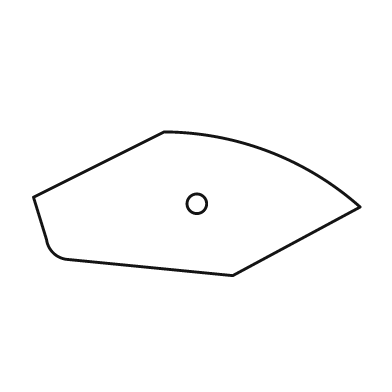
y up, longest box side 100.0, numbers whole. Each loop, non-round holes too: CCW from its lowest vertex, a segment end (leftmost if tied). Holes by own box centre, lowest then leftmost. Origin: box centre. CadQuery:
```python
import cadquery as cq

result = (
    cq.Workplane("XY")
    .moveTo(11.0, -22.0)
    .lineTo(50.0, -1.0)
    .threePointArc((22.0, 16.0), (-10.0, 22.0))
    .lineTo(-50.0, 2.0)
    .lineTo(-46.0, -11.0)
    .threePointArc((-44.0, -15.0), (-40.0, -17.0))
    .close()
    .moveTo(0.0, 0.0)
    .circle(3.0)
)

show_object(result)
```